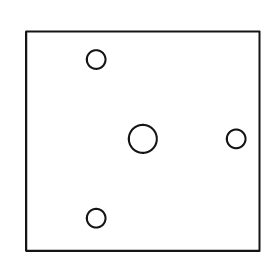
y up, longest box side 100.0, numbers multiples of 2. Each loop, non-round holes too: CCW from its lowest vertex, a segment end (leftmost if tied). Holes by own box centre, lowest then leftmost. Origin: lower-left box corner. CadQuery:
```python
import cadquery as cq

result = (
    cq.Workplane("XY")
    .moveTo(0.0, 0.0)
    .lineTo(100.0, 0.0)
    .lineTo(100.0, 94.0)
    .lineTo(0.0, 94.0)
    .close()
    .moveTo(30.0, 14.0)
    .circle(4.0)
    .moveTo(50.0, 48.0)
    .circle(6.0)
    .moveTo(90.0, 48.0)
    .circle(4.0)
    .moveTo(30.0, 82.0)
    .circle(4.0)
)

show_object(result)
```